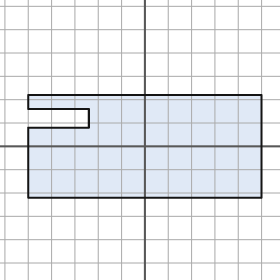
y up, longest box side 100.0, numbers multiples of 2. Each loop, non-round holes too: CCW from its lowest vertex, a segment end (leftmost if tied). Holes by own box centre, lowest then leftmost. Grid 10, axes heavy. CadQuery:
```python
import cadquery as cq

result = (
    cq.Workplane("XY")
    .moveTo(-50.0, -22.0)
    .lineTo(50.0, -22.0)
    .lineTo(50.0, 22.0)
    .lineTo(-50.0, 22.0)
    .lineTo(-50.0, 16.0)
    .lineTo(-24.0, 16.0)
    .lineTo(-24.0, 8.0)
    .lineTo(-50.0, 8.0)
    .close()
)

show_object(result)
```